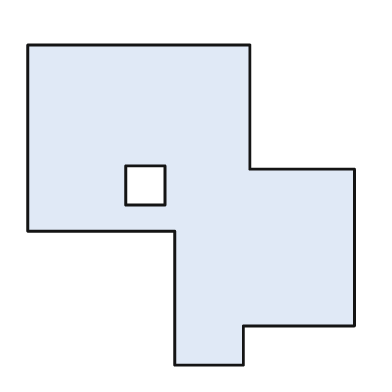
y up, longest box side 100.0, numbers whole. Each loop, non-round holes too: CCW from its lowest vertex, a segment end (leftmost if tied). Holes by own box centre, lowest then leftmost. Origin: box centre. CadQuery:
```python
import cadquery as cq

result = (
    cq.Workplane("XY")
    .moveTo(-5.0, -49.0)
    .lineTo(16.0, -49.0)
    .lineTo(16.0, -37.0)
    .lineTo(50.0, -37.0)
    .lineTo(50.0, 11.0)
    .lineTo(18.0, 11.0)
    .lineTo(18.0, 49.0)
    .lineTo(-50.0, 49.0)
    .lineTo(-50.0, -8.0)
    .lineTo(-5.0, -8.0)
    .close()
    .moveTo(-20.0, 0.0)
    .lineTo(-8.0, 0.0)
    .lineTo(-8.0, 12.0)
    .lineTo(-20.0, 12.0)
    .close()
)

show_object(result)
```